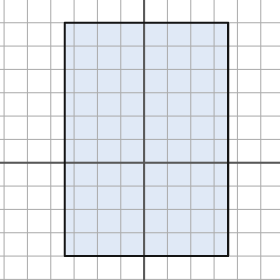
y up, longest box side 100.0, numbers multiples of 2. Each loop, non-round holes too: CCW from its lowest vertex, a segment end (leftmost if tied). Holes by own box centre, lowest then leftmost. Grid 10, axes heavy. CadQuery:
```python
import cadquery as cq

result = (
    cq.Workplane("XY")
    .moveTo(-34.0, -40.0)
    .lineTo(36.0, -40.0)
    .lineTo(36.0, 60.0)
    .lineTo(-34.0, 60.0)
    .close()
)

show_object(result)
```